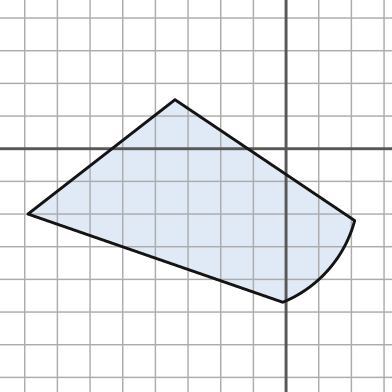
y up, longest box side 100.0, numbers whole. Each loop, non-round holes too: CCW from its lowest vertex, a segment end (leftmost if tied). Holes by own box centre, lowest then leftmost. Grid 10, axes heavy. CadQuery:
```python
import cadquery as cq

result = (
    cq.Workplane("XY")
    .moveTo(-1.0, -47.0)
    .threePointArc((13.0, -37.0), (21.0, -22.0))
    .lineTo(-34.0, 15.0)
    .lineTo(-79.0, -20.0)
    .close()
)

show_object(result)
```